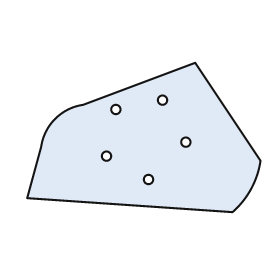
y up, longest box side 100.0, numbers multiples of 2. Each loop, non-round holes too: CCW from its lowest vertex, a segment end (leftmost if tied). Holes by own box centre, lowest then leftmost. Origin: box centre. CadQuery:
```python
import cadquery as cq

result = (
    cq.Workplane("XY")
    .moveTo(38.0, -32.0)
    .threePointArc((46.0, -22.0), (50.0, -10.0))
    .lineTo(22.0, 32.0)
    .lineTo(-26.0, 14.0)
    .threePointArc((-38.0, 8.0), (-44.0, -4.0))
    .lineTo(-50.0, -26.0)
    .close()
    .moveTo(2.0, -18.0)
    .circle(2.0)
    .moveTo(-16.0, -8.0)
    .circle(2.0)
    .moveTo(18.0, -2.0)
    .circle(2.0)
    .moveTo(-12.0, 12.0)
    .circle(2.0)
    .moveTo(8.0, 16.0)
    .circle(2.0)
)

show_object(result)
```